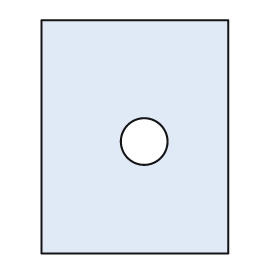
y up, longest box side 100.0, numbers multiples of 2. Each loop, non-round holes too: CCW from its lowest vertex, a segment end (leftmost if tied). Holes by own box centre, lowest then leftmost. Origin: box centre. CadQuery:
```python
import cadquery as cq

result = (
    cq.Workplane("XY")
    .moveTo(-40.0, -50.0)
    .lineTo(40.0, -50.0)
    .lineTo(40.0, 50.0)
    .lineTo(-40.0, 50.0)
    .close()
    .moveTo(4.0, -2.0)
    .circle(10.0)
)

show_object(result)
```